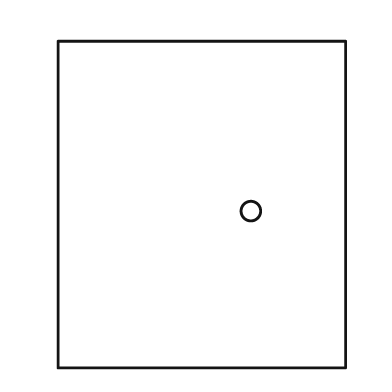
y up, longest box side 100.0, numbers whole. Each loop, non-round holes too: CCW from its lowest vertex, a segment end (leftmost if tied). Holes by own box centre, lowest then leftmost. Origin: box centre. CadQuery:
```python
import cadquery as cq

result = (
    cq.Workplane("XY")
    .moveTo(-44.0, -50.0)
    .lineTo(44.0, -50.0)
    .lineTo(44.0, 50.0)
    .lineTo(-44.0, 50.0)
    .close()
    .moveTo(15.0, -2.0)
    .circle(3.0)
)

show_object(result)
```